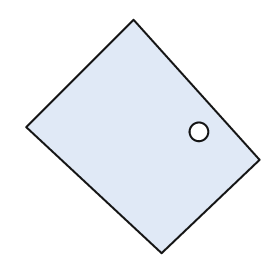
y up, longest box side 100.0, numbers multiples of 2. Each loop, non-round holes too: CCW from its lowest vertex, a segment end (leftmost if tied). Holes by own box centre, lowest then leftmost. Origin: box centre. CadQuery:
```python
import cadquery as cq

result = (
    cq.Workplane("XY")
    .moveTo(8.0, -50.0)
    .lineTo(50.0, -10.0)
    .lineTo(-4.0, 50.0)
    .lineTo(-50.0, 4.0)
    .close()
    .moveTo(24.0, 2.0)
    .circle(4.0)
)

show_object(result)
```